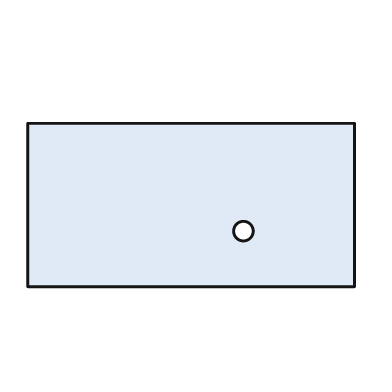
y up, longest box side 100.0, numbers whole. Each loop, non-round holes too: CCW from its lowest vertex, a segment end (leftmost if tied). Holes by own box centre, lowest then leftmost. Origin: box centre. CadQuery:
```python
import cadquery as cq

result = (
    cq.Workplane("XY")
    .moveTo(-50.0, -25.0)
    .lineTo(50.0, -25.0)
    .lineTo(50.0, 25.0)
    .lineTo(-50.0, 25.0)
    .close()
    .moveTo(16.0, -8.0)
    .circle(3.0)
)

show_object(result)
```